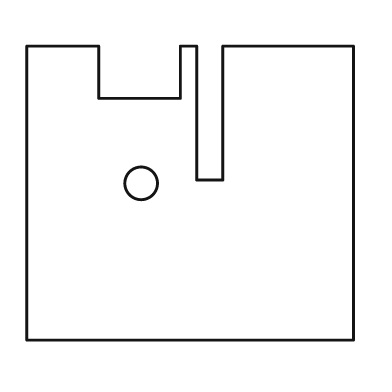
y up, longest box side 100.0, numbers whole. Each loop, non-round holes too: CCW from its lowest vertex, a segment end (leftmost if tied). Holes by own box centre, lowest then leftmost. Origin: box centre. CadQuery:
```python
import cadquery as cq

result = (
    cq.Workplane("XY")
    .moveTo(-50.0, -45.0)
    .lineTo(50.0, -45.0)
    .lineTo(50.0, 45.0)
    .lineTo(10.0, 45.0)
    .lineTo(10.0, 4.0)
    .lineTo(2.0, 4.0)
    .lineTo(2.0, 45.0)
    .lineTo(-3.0, 45.0)
    .lineTo(-3.0, 29.0)
    .lineTo(-28.0, 29.0)
    .lineTo(-28.0, 45.0)
    .lineTo(-50.0, 45.0)
    .close()
    .moveTo(-15.0, 3.0)
    .circle(5.0)
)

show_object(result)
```